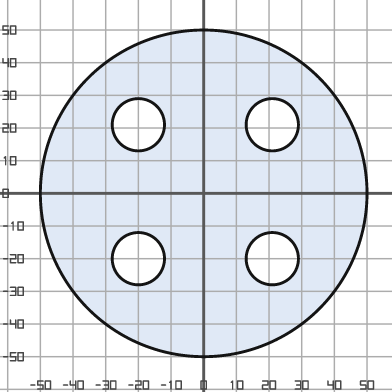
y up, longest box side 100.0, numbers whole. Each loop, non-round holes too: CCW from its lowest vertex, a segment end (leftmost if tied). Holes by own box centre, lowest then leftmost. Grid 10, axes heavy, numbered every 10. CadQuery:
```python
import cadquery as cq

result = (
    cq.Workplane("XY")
    .moveTo(0.0, 0.0)
    .circle(50.0)
    .moveTo(-20.0, -20.0)
    .circle(8.0)
    .moveTo(21.0, -20.0)
    .circle(8.0)
    .moveTo(-20.0, 21.0)
    .circle(8.0)
    .moveTo(21.0, 21.0)
    .circle(8.0)
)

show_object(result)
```